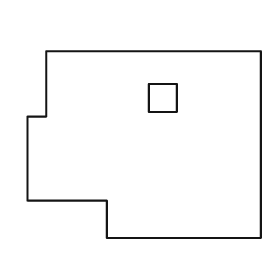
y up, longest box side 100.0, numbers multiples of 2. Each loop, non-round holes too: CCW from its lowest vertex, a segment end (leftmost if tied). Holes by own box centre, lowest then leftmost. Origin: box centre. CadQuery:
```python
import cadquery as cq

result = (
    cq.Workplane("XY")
    .moveTo(-16.0, -40.0)
    .lineTo(50.0, -40.0)
    .lineTo(50.0, 40.0)
    .lineTo(-42.0, 40.0)
    .lineTo(-42.0, 12.0)
    .lineTo(-50.0, 12.0)
    .lineTo(-50.0, -24.0)
    .lineTo(-16.0, -24.0)
    .close()
    .moveTo(2.0, 14.0)
    .lineTo(14.0, 14.0)
    .lineTo(14.0, 26.0)
    .lineTo(2.0, 26.0)
    .close()
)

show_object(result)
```